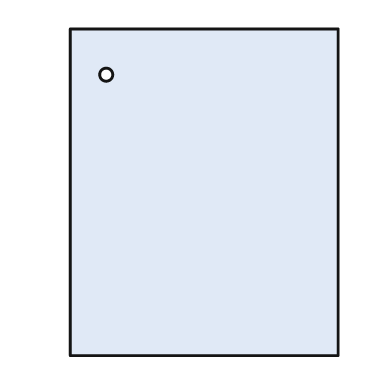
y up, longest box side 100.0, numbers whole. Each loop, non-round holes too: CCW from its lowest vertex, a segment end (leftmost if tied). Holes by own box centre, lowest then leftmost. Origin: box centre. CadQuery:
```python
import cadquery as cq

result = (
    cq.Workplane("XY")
    .moveTo(-41.0, -50.0)
    .lineTo(41.0, -50.0)
    .lineTo(41.0, 50.0)
    .lineTo(-41.0, 50.0)
    .close()
    .moveTo(-30.0, 36.0)
    .circle(2.0)
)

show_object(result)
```